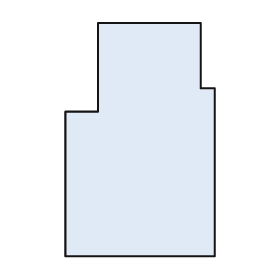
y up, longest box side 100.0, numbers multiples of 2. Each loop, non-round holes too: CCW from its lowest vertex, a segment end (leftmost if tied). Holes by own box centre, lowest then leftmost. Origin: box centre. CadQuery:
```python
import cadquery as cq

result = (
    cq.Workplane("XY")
    .moveTo(-32.0, -50.0)
    .lineTo(32.0, -50.0)
    .lineTo(32.0, 22.0)
    .lineTo(26.0, 22.0)
    .lineTo(26.0, 50.0)
    .lineTo(-18.0, 50.0)
    .lineTo(-18.0, 12.0)
    .lineTo(-32.0, 12.0)
    .close()
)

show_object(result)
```